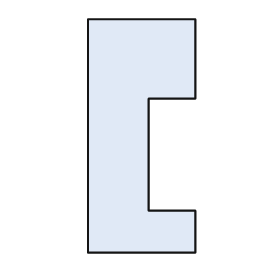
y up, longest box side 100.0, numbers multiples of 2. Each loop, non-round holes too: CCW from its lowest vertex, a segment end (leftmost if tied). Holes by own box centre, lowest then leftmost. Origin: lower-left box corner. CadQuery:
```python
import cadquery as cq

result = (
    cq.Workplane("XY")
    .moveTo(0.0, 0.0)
    .lineTo(46.0, 0.0)
    .lineTo(46.0, 18.0)
    .lineTo(26.0, 18.0)
    .lineTo(26.0, 66.0)
    .lineTo(46.0, 66.0)
    .lineTo(46.0, 100.0)
    .lineTo(0.0, 100.0)
    .close()
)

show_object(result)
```